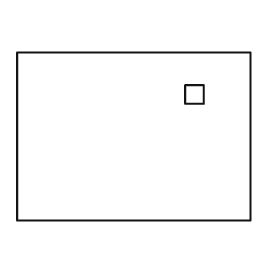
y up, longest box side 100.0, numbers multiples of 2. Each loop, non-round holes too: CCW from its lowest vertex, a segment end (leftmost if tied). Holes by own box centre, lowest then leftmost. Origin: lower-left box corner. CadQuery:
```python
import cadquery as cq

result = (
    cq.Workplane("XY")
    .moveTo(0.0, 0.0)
    .lineTo(100.0, 0.0)
    .lineTo(100.0, 72.0)
    .lineTo(0.0, 72.0)
    .close()
    .moveTo(72.0, 50.0)
    .lineTo(80.0, 50.0)
    .lineTo(80.0, 58.0)
    .lineTo(72.0, 58.0)
    .close()
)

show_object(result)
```